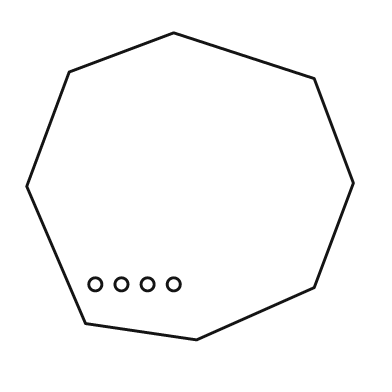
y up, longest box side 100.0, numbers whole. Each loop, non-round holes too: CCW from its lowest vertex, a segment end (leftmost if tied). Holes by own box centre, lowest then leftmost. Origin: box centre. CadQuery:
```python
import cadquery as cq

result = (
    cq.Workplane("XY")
    .moveTo(2.0, -47.0)
    .lineTo(38.0, -31.0)
    .lineTo(50.0, 1.0)
    .lineTo(38.0, 33.0)
    .lineTo(-5.0, 47.0)
    .lineTo(-37.0, 35.0)
    .lineTo(-50.0, 0.0)
    .lineTo(-32.0, -42.0)
    .close()
    .moveTo(-29.0, -30.0)
    .circle(2.0)
    .moveTo(-21.0, -30.0)
    .circle(2.0)
    .moveTo(-13.0, -30.0)
    .circle(2.0)
    .moveTo(-5.0, -30.0)
    .circle(2.0)
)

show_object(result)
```